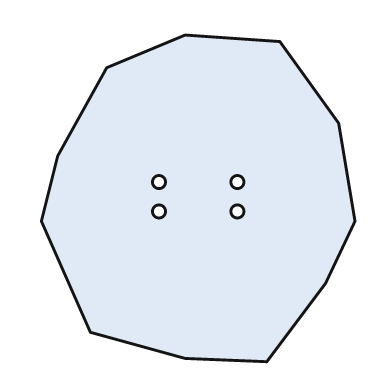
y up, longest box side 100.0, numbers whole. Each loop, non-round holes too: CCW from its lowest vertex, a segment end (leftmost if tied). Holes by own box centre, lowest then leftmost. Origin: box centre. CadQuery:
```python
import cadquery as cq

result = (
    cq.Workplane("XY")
    .moveTo(21.0, -50.0)
    .lineTo(39.0, -26.0)
    .lineTo(48.0, -7.0)
    .lineTo(43.0, 23.0)
    .lineTo(25.0, 48.0)
    .lineTo(-4.0, 50.0)
    .lineTo(-28.0, 40.0)
    .lineTo(-43.0, 13.0)
    .lineTo(-48.0, -7.0)
    .lineTo(-33.0, -41.0)
    .lineTo(-4.0, -49.0)
    .close()
    .moveTo(-12.0, -4.0)
    .circle(2.0)
    .moveTo(12.0, -4.0)
    .circle(2.0)
    .moveTo(-12.0, 5.0)
    .circle(2.0)
    .moveTo(12.0, 5.0)
    .circle(2.0)
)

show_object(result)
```